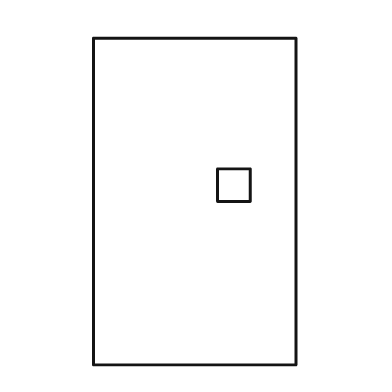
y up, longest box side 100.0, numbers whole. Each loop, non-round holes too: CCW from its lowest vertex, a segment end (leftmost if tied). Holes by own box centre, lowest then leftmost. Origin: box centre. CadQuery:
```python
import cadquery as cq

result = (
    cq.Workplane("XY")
    .moveTo(-31.0, -50.0)
    .lineTo(31.0, -50.0)
    .lineTo(31.0, 50.0)
    .lineTo(-31.0, 50.0)
    .close()
    .moveTo(7.0, 0.0)
    .lineTo(17.0, 0.0)
    .lineTo(17.0, 10.0)
    .lineTo(7.0, 10.0)
    .close()
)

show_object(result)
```